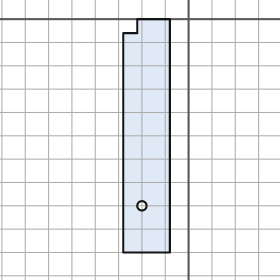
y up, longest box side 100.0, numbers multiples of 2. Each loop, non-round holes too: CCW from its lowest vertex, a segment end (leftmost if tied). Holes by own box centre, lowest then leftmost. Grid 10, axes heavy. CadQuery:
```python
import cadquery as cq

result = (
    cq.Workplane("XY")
    .moveTo(-28.0, -100.0)
    .lineTo(-8.0, -100.0)
    .lineTo(-8.0, 0.0)
    .lineTo(-22.0, 0.0)
    .lineTo(-22.0, -6.0)
    .lineTo(-28.0, -6.0)
    .close()
    .moveTo(-20.0, -80.0)
    .circle(2.0)
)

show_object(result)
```